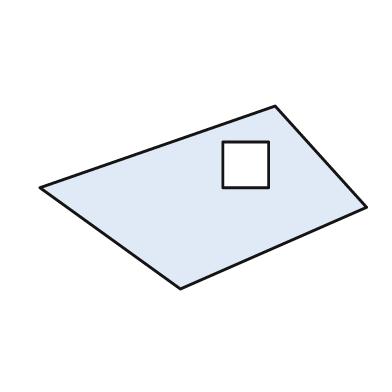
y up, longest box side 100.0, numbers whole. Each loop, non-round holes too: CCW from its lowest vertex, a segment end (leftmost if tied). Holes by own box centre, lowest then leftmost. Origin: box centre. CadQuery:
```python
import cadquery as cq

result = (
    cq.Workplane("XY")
    .moveTo(-7.0, -28.0)
    .lineTo(50.0, -3.0)
    .lineTo(22.0, 28.0)
    .lineTo(-50.0, 3.0)
    .close()
    .moveTo(6.0, 3.0)
    .lineTo(20.0, 3.0)
    .lineTo(20.0, 17.0)
    .lineTo(6.0, 17.0)
    .close()
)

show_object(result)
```